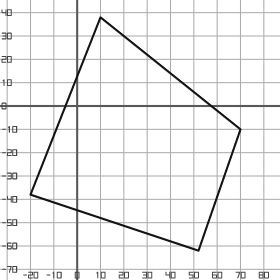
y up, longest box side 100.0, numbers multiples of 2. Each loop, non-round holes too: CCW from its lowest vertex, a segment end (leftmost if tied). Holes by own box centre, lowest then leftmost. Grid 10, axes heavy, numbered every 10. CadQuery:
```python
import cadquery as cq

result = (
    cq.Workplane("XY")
    .moveTo(52.0, -62.0)
    .lineTo(70.0, -10.0)
    .lineTo(10.0, 38.0)
    .lineTo(-20.0, -38.0)
    .close()
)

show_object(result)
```